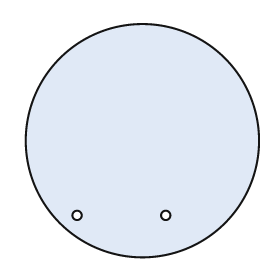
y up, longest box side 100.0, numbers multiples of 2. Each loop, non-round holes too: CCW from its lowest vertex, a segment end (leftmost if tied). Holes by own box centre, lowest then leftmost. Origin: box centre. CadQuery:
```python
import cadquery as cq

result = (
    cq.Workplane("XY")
    .moveTo(0.0, 0.0)
    .circle(50.0)
    .moveTo(-28.0, -32.0)
    .circle(2.0)
    .moveTo(10.0, -32.0)
    .circle(2.0)
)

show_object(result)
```